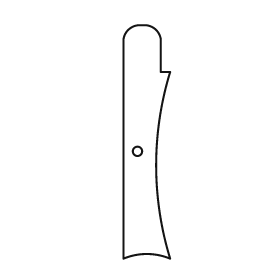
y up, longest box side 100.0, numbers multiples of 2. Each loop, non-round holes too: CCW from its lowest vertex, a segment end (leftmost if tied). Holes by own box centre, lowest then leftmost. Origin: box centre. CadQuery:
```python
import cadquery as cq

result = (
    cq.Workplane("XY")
    .moveTo(-10.0, -50.0)
    .threePointArc((0.0, -48.0), (10.0, -50.0))
    .threePointArc((4.0, -10.0), (10.0, 30.0))
    .lineTo(6.0, 30.0)
    .lineTo(6.0, 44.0)
    .threePointArc((4.0, 48.0), (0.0, 50.0))
    .lineTo(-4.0, 50.0)
    .threePointArc((-8.0, 48.0), (-10.0, 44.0))
    .close()
    .moveTo(-4.0, -4.0)
    .circle(2.0)
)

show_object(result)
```